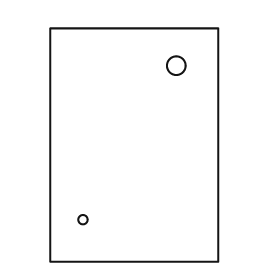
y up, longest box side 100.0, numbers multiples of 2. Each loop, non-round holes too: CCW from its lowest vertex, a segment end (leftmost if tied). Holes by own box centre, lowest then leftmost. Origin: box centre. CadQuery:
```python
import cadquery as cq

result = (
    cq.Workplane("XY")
    .moveTo(-36.0, -50.0)
    .lineTo(36.0, -50.0)
    .lineTo(36.0, 50.0)
    .lineTo(-36.0, 50.0)
    .close()
    .moveTo(-22.0, -32.0)
    .circle(2.0)
    .moveTo(18.0, 34.0)
    .circle(4.0)
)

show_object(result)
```